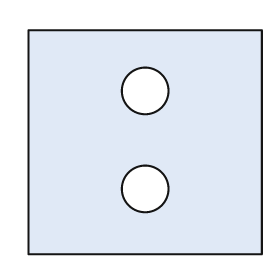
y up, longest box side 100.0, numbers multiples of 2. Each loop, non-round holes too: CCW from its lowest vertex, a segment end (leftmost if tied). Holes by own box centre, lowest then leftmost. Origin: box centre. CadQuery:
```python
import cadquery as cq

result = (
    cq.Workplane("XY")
    .moveTo(-50.0, -48.0)
    .lineTo(50.0, -48.0)
    .lineTo(50.0, 48.0)
    .lineTo(-50.0, 48.0)
    .close()
    .moveTo(0.0, -20.0)
    .circle(10.0)
    .moveTo(0.0, 22.0)
    .circle(10.0)
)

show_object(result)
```